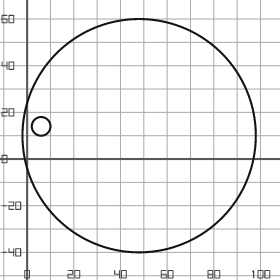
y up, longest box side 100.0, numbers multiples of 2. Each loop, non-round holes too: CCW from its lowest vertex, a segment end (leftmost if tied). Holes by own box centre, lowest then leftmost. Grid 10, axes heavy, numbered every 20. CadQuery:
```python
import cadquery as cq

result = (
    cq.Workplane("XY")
    .moveTo(48.0, 10.0)
    .circle(50.0)
    .moveTo(6.0, 14.0)
    .circle(4.0)
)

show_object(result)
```